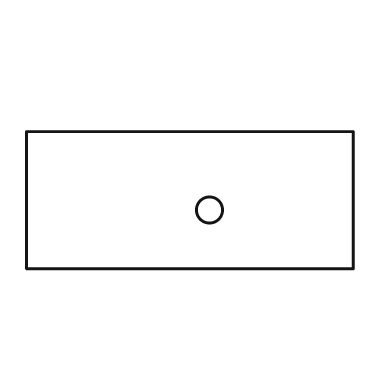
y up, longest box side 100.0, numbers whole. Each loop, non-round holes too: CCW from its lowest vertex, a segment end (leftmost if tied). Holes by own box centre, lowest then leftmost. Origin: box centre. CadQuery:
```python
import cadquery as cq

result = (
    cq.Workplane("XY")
    .moveTo(-50.0, -21.0)
    .lineTo(50.0, -21.0)
    .lineTo(50.0, 21.0)
    .lineTo(-50.0, 21.0)
    .close()
    .moveTo(6.0, -3.0)
    .circle(4.0)
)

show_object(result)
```